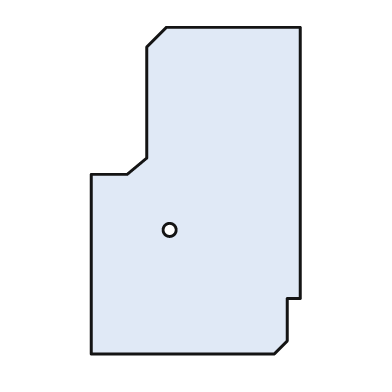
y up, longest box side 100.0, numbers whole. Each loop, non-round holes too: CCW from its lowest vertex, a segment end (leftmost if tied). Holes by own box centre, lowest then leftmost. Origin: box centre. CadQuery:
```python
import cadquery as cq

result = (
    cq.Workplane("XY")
    .moveTo(-32.0, -50.0)
    .lineTo(24.0, -50.0)
    .lineTo(28.0, -46.0)
    .lineTo(28.0, -33.0)
    .lineTo(32.0, -33.0)
    .lineTo(32.0, 50.0)
    .lineTo(-9.0, 50.0)
    .lineTo(-15.0, 44.0)
    .lineTo(-15.0, 10.0)
    .lineTo(-21.0, 5.0)
    .lineTo(-32.0, 5.0)
    .close()
    .moveTo(-8.0, -12.0)
    .circle(2.0)
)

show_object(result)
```